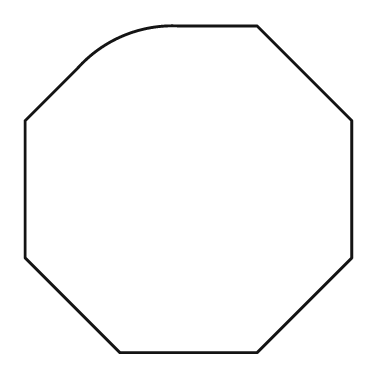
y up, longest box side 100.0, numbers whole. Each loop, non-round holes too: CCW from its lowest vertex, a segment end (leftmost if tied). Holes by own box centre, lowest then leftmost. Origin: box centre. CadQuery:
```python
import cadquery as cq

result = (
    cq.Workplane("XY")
    .moveTo(-21.0, -50.0)
    .lineTo(21.0, -50.0)
    .lineTo(50.0, -21.0)
    .lineTo(50.0, 21.0)
    .lineTo(21.0, 50.0)
    .lineTo(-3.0, 50.0)
    .threePointArc((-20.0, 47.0), (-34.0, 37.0))
    .lineTo(-50.0, 21.0)
    .lineTo(-50.0, -21.0)
    .close()
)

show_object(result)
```